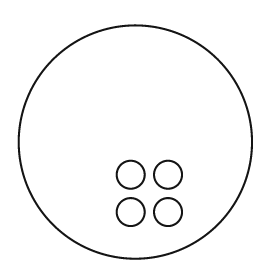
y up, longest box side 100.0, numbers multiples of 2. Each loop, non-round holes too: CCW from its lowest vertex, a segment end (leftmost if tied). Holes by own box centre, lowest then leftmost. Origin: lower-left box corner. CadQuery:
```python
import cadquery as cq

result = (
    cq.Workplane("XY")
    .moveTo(50.0, 50.0)
    .circle(50.0)
    .moveTo(48.0, 20.0)
    .circle(6.0)
    .moveTo(64.0, 20.0)
    .circle(6.0)
    .moveTo(48.0, 36.0)
    .circle(6.0)
    .moveTo(64.0, 36.0)
    .circle(6.0)
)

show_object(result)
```